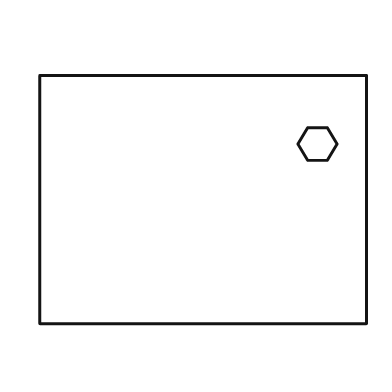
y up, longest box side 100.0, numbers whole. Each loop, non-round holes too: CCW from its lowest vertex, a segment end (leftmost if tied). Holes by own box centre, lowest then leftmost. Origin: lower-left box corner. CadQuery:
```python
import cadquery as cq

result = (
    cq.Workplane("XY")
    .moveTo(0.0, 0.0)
    .lineTo(100.0, 0.0)
    .lineTo(100.0, 76.0)
    .lineTo(0.0, 76.0)
    .close()
    .moveTo(82.0, 50.0)
    .lineTo(88.0, 50.0)
    .lineTo(91.0, 55.0)
    .lineTo(88.0, 60.0)
    .lineTo(82.0, 60.0)
    .lineTo(79.0, 55.0)
    .close()
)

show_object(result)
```